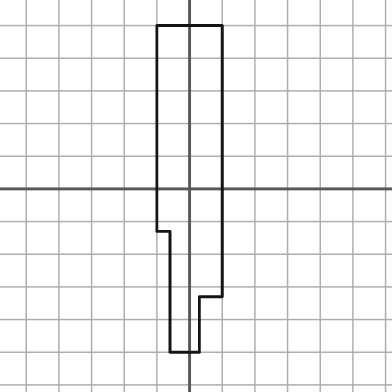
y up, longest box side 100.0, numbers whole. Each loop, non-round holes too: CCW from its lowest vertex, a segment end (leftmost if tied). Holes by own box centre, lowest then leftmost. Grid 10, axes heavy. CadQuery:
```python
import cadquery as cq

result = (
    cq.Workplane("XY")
    .moveTo(-6.0, -50.0)
    .lineTo(3.0, -50.0)
    .lineTo(3.0, -33.0)
    .lineTo(10.0, -33.0)
    .lineTo(10.0, 50.0)
    .lineTo(-10.0, 50.0)
    .lineTo(-10.0, -13.0)
    .lineTo(-6.0, -13.0)
    .close()
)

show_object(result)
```